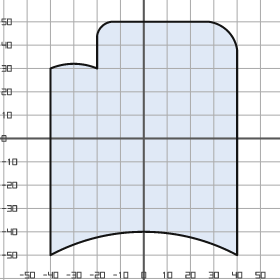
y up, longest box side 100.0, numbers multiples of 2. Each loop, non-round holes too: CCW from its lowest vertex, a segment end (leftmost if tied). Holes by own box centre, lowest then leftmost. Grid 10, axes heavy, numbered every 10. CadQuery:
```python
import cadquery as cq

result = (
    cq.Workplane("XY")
    .moveTo(-40.0, -50.0)
    .threePointArc((0.0, -40.0), (40.0, -50.0))
    .lineTo(40.0, 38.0)
    .threePointArc((36.0, 46.0), (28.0, 50.0))
    .lineTo(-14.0, 50.0)
    .threePointArc((-18.0, 48.0), (-20.0, 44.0))
    .lineTo(-20.0, 30.0)
    .threePointArc((-30.0, 32.0), (-40.0, 30.0))
    .close()
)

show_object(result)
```